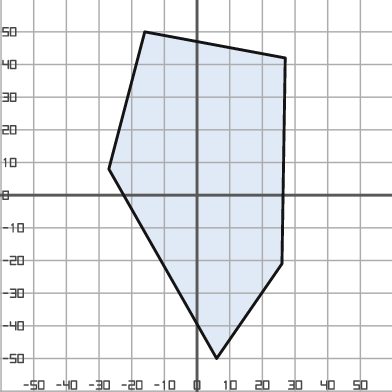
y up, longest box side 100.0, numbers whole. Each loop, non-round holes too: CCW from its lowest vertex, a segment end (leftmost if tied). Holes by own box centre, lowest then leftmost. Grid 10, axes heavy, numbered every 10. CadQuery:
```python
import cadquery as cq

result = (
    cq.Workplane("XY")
    .moveTo(6.0, -50.0)
    .lineTo(26.0, -21.0)
    .lineTo(27.0, 42.0)
    .lineTo(-16.0, 50.0)
    .lineTo(-27.0, 8.0)
    .close()
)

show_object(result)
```